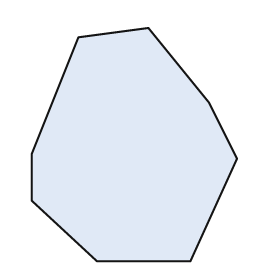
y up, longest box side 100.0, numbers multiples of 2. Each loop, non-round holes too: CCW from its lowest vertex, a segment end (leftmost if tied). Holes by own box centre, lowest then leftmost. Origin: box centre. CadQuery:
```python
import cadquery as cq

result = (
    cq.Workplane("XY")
    .moveTo(-16.0, -50.0)
    .lineTo(24.0, -50.0)
    .lineTo(44.0, -6.0)
    .lineTo(32.0, 18.0)
    .lineTo(6.0, 50.0)
    .lineTo(-24.0, 46.0)
    .lineTo(-44.0, -4.0)
    .lineTo(-44.0, -24.0)
    .close()
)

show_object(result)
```